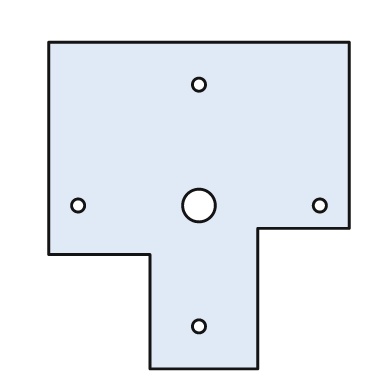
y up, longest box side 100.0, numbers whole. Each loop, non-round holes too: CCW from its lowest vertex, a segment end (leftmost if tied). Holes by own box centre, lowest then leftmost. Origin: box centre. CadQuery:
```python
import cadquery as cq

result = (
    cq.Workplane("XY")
    .moveTo(-15.0, -50.0)
    .lineTo(18.0, -50.0)
    .lineTo(18.0, -7.0)
    .lineTo(46.0, -7.0)
    .lineTo(46.0, 50.0)
    .lineTo(-46.0, 50.0)
    .lineTo(-46.0, -15.0)
    .lineTo(-15.0, -15.0)
    .close()
    .moveTo(0.0, -37.0)
    .circle(2.0)
    .moveTo(-37.0, 0.0)
    .circle(2.0)
    .moveTo(0.0, 0.0)
    .circle(5.0)
    .moveTo(37.0, 0.0)
    .circle(2.0)
    .moveTo(0.0, 37.0)
    .circle(2.0)
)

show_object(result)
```